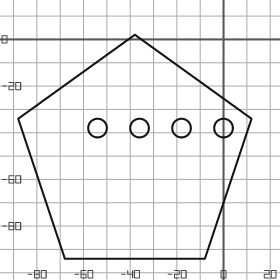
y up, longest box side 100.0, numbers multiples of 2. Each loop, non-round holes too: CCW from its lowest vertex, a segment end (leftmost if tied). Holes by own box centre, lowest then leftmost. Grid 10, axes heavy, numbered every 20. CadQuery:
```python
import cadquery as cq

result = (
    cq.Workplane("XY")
    .moveTo(-68.0, -94.0)
    .lineTo(-8.0, -94.0)
    .lineTo(12.0, -34.0)
    .lineTo(-38.0, 2.0)
    .lineTo(-88.0, -34.0)
    .close()
    .moveTo(-54.0, -38.0)
    .circle(4.0)
    .moveTo(-36.0, -38.0)
    .circle(4.0)
    .moveTo(-18.0, -38.0)
    .circle(4.0)
    .moveTo(0.0, -38.0)
    .circle(4.0)
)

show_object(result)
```